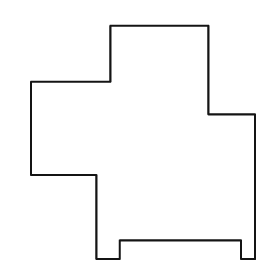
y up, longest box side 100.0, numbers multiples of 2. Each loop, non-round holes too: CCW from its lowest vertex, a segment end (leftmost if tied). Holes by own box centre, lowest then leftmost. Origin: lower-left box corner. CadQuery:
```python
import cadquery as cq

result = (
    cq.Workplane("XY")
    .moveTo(28.0, 0.0)
    .lineTo(38.0, 0.0)
    .lineTo(38.0, 8.0)
    .lineTo(90.0, 8.0)
    .lineTo(90.0, 0.0)
    .lineTo(96.0, 0.0)
    .lineTo(96.0, 62.0)
    .lineTo(76.0, 62.0)
    .lineTo(76.0, 100.0)
    .lineTo(34.0, 100.0)
    .lineTo(34.0, 76.0)
    .lineTo(0.0, 76.0)
    .lineTo(0.0, 36.0)
    .lineTo(28.0, 36.0)
    .close()
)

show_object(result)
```